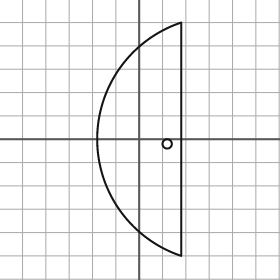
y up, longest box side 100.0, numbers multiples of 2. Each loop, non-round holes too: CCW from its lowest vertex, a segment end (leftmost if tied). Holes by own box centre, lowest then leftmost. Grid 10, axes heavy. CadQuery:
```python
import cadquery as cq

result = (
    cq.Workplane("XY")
    .moveTo(18.0, -50.0)
    .lineTo(18.0, 50.0)
    .threePointArc((-18.0, 0.0), (18.0, -50.0))
    .close()
    .moveTo(12.0, -2.0)
    .circle(2.0)
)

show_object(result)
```